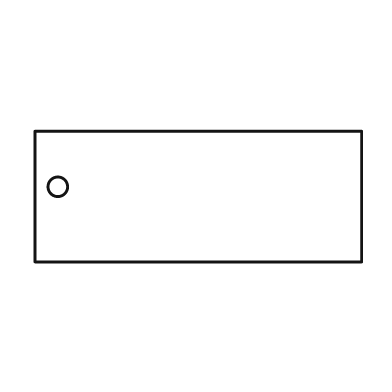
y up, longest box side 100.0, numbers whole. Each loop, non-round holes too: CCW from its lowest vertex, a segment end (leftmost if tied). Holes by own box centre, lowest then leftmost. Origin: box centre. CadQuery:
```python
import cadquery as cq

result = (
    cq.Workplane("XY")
    .moveTo(-50.0, -20.0)
    .lineTo(50.0, -20.0)
    .lineTo(50.0, 20.0)
    .lineTo(-50.0, 20.0)
    .close()
    .moveTo(-43.0, 3.0)
    .circle(3.0)
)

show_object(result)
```